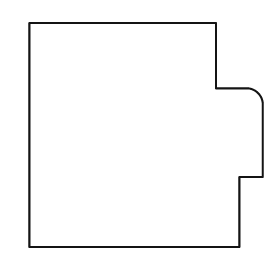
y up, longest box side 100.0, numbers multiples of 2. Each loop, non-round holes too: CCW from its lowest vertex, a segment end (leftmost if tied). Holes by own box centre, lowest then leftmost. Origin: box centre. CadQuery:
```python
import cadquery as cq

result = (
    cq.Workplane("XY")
    .moveTo(-50.0, -48.0)
    .lineTo(40.0, -48.0)
    .lineTo(40.0, -18.0)
    .lineTo(50.0, -18.0)
    .lineTo(50.0, 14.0)
    .threePointArc((48.0, 18.0), (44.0, 20.0))
    .lineTo(30.0, 20.0)
    .lineTo(30.0, 48.0)
    .lineTo(-50.0, 48.0)
    .close()
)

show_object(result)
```